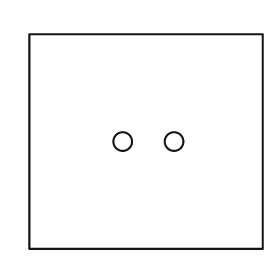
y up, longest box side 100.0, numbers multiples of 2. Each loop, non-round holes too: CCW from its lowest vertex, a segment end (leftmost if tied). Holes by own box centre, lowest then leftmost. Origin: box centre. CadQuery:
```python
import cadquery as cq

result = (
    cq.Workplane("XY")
    .moveTo(-50.0, -46.0)
    .lineTo(50.0, -46.0)
    .lineTo(50.0, 46.0)
    .lineTo(-50.0, 46.0)
    .close()
    .moveTo(-10.0, 0.0)
    .circle(4.0)
    .moveTo(12.0, 0.0)
    .circle(4.0)
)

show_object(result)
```